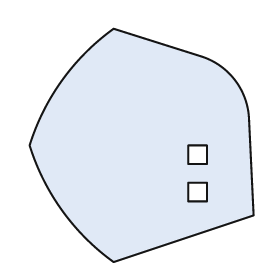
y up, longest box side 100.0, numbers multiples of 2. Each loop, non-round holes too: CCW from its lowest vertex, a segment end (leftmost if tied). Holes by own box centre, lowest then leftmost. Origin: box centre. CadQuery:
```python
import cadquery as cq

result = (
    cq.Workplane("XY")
    .moveTo(-12.0, -50.0)
    .lineTo(48.0, -30.0)
    .lineTo(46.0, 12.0)
    .threePointArc((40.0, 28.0), (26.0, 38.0))
    .lineTo(-12.0, 50.0)
    .threePointArc((-34.0, 28.0), (-48.0, 0.0))
    .threePointArc((-34.0, -28.0), (-12.0, -50.0))
    .close()
    .moveTo(20.0, -24.0)
    .lineTo(28.0, -24.0)
    .lineTo(28.0, -16.0)
    .lineTo(20.0, -16.0)
    .close()
    .moveTo(20.0, -8.0)
    .lineTo(28.0, -8.0)
    .lineTo(28.0, 0.0)
    .lineTo(20.0, 0.0)
    .close()
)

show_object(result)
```